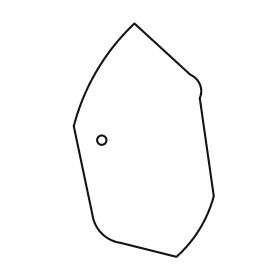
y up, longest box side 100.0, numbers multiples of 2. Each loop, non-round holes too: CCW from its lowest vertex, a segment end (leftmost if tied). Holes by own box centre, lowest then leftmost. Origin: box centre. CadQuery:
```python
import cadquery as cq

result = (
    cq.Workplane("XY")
    .moveTo(14.0, -50.0)
    .threePointArc((24.0, -38.0), (30.0, -24.0))
    .lineTo(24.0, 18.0)
    .threePointArc((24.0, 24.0), (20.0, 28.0))
    .lineTo(-4.0, 50.0)
    .threePointArc((-20.0, 30.0), (-30.0, 6.0))
    .lineTo(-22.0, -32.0)
    .threePointArc((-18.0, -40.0), (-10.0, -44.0))
    .close()
    .moveTo(-18.0, 0.0)
    .circle(2.0)
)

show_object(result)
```